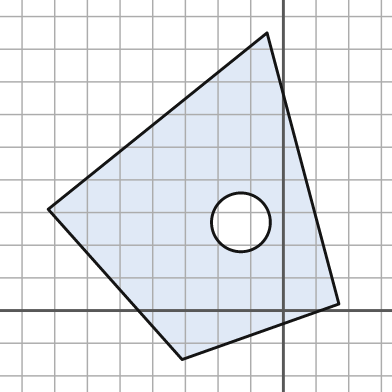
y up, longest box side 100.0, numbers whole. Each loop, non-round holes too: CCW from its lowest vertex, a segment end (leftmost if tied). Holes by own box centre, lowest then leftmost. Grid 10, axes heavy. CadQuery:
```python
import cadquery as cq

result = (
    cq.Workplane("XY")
    .moveTo(-31.0, -15.0)
    .lineTo(17.0, 2.0)
    .lineTo(-5.0, 85.0)
    .lineTo(-72.0, 31.0)
    .close()
    .moveTo(-13.0, 27.0)
    .circle(9.0)
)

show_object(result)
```